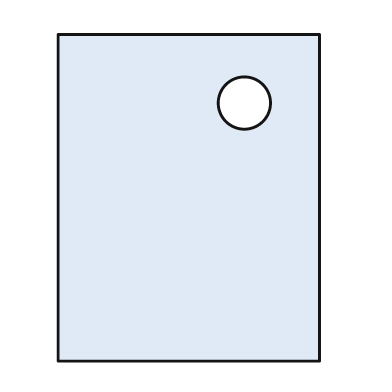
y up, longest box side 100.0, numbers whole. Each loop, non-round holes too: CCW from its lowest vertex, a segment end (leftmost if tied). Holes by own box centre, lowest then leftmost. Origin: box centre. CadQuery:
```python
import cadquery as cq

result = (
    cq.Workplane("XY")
    .moveTo(-40.0, -50.0)
    .lineTo(40.0, -50.0)
    .lineTo(40.0, 50.0)
    .lineTo(-40.0, 50.0)
    .close()
    .moveTo(17.0, 29.0)
    .circle(8.0)
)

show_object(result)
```